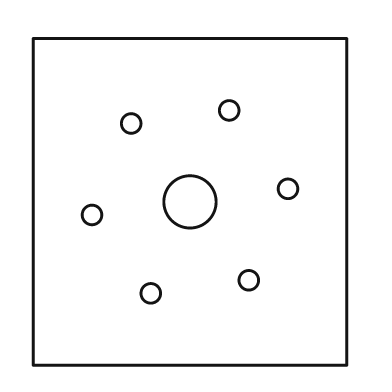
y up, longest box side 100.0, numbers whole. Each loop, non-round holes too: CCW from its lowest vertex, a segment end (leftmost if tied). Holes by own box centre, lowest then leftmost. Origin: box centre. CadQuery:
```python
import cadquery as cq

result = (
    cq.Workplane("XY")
    .moveTo(-48.0, -50.0)
    .lineTo(48.0, -50.0)
    .lineTo(48.0, 50.0)
    .lineTo(-48.0, 50.0)
    .close()
    .moveTo(-12.0, -28.0)
    .circle(3.0)
    .moveTo(18.0, -24.0)
    .circle(3.0)
    .moveTo(-30.0, -4.0)
    .circle(3.0)
    .moveTo(0.0, 0.0)
    .circle(8.0)
    .moveTo(30.0, 4.0)
    .circle(3.0)
    .moveTo(-18.0, 24.0)
    .circle(3.0)
    .moveTo(12.0, 28.0)
    .circle(3.0)
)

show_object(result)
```